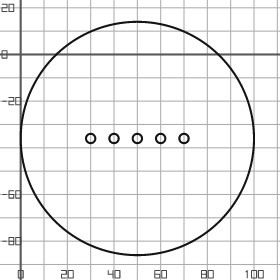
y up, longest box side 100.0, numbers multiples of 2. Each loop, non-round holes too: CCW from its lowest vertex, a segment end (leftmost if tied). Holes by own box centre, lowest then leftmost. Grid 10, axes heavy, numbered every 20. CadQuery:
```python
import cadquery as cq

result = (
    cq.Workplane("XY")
    .moveTo(50.0, -36.0)
    .circle(50.0)
    .moveTo(30.0, -36.0)
    .circle(2.0)
    .moveTo(40.0, -36.0)
    .circle(2.0)
    .moveTo(50.0, -36.0)
    .circle(2.0)
    .moveTo(60.0, -36.0)
    .circle(2.0)
    .moveTo(70.0, -36.0)
    .circle(2.0)
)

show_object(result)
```